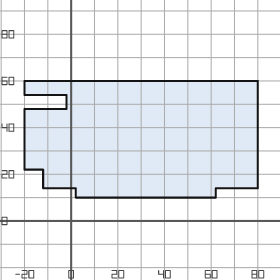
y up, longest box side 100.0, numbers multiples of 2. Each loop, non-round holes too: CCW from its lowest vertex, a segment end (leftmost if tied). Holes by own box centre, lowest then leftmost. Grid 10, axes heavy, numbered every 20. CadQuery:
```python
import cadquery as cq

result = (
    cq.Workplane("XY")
    .moveTo(2.0, 10.0)
    .lineTo(62.0, 10.0)
    .lineTo(62.0, 14.0)
    .lineTo(80.0, 14.0)
    .lineTo(80.0, 60.0)
    .lineTo(-20.0, 60.0)
    .lineTo(-20.0, 54.0)
    .lineTo(-2.0, 54.0)
    .lineTo(-2.0, 48.0)
    .lineTo(-20.0, 48.0)
    .lineTo(-20.0, 22.0)
    .lineTo(-12.0, 22.0)
    .lineTo(-12.0, 14.0)
    .lineTo(2.0, 14.0)
    .close()
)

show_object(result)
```